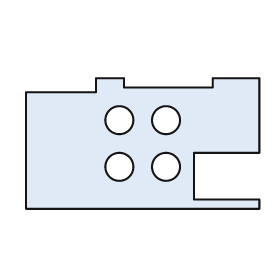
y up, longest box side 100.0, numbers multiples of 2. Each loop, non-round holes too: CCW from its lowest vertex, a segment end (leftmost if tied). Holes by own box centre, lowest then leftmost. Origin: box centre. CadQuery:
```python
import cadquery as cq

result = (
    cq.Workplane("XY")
    .moveTo(-50.0, -28.0)
    .lineTo(50.0, -28.0)
    .lineTo(50.0, -24.0)
    .lineTo(22.0, -24.0)
    .lineTo(22.0, -4.0)
    .lineTo(50.0, -4.0)
    .lineTo(50.0, 28.0)
    .lineTo(30.0, 28.0)
    .lineTo(30.0, 24.0)
    .lineTo(-8.0, 24.0)
    .lineTo(-8.0, 28.0)
    .lineTo(-20.0, 28.0)
    .lineTo(-20.0, 22.0)
    .lineTo(-50.0, 22.0)
    .close()
    .moveTo(-10.0, -10.0)
    .circle(6.0)
    .moveTo(10.0, -10.0)
    .circle(6.0)
    .moveTo(-10.0, 10.0)
    .circle(6.0)
    .moveTo(10.0, 10.0)
    .circle(6.0)
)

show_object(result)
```